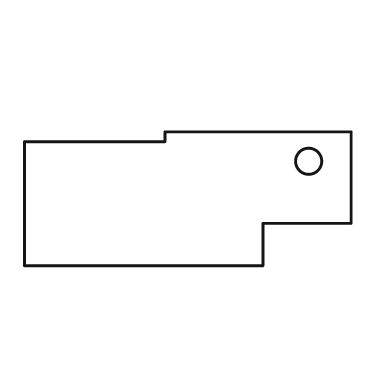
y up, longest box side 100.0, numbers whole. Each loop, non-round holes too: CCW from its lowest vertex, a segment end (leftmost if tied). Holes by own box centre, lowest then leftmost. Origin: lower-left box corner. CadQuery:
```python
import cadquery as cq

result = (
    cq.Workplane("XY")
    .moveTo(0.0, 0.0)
    .lineTo(73.0, 0.0)
    .lineTo(73.0, 13.0)
    .lineTo(100.0, 13.0)
    .lineTo(100.0, 41.0)
    .lineTo(43.0, 41.0)
    .lineTo(43.0, 38.0)
    .lineTo(0.0, 38.0)
    .close()
    .moveTo(87.0, 32.0)
    .circle(4.0)
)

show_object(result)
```